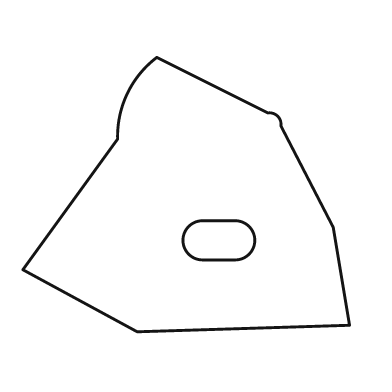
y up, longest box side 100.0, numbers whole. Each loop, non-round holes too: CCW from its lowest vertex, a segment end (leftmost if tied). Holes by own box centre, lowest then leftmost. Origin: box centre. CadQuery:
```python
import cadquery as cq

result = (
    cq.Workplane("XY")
    .moveTo(-15.0, -42.0)
    .lineTo(50.0, -40.0)
    .lineTo(45.0, -10.0)
    .lineTo(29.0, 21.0)
    .threePointArc((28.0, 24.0), (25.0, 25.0))
    .lineTo(-9.0, 42.0)
    .threePointArc((-18.0, 31.0), (-21.0, 17.0))
    .lineTo(-50.0, -23.0)
    .close()
    .moveTo(5.0, -20.0)
    .lineTo(15.0, -20.0)
    .threePointArc((21.0, -14.0), (15.0, -8.0))
    .lineTo(5.0, -8.0)
    .threePointArc((-1.0, -14.0), (5.0, -20.0))
    .close()
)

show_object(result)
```